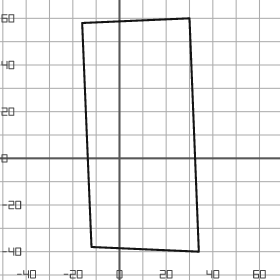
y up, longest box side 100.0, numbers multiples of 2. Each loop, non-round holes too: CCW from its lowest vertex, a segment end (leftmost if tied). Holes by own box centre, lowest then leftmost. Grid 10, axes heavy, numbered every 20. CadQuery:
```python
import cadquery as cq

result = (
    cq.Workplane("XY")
    .moveTo(34.0, -40.0)
    .lineTo(30.0, 60.0)
    .lineTo(-16.0, 58.0)
    .lineTo(-12.0, -38.0)
    .close()
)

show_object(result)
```